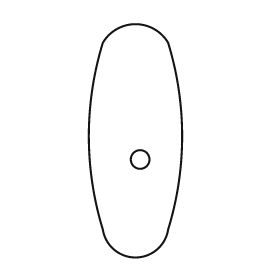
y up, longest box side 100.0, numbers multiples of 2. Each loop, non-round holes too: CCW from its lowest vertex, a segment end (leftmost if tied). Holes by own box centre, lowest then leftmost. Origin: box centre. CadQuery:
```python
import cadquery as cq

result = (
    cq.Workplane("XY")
    .moveTo(-14.0, -38.0)
    .threePointArc((0.0, -50.0), (14.0, -38.0))
    .threePointArc((20.0, 2.0), (14.0, 42.0))
    .threePointArc((0.0, 50.0), (-14.0, 42.0))
    .threePointArc((-20.0, 2.0), (-14.0, -38.0))
    .close()
    .moveTo(2.0, -8.0)
    .circle(4.0)
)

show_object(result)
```